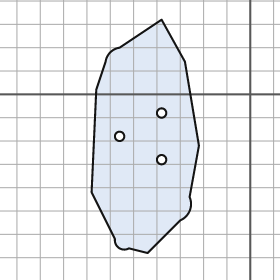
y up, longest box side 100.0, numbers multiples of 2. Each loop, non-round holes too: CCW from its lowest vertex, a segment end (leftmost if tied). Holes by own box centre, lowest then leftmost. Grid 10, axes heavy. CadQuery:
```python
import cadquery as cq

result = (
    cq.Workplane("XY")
    .moveTo(-44.0, -68.0)
    .lineTo(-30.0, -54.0)
    .threePointArc((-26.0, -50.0), (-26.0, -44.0))
    .lineTo(-22.0, -22.0)
    .lineTo(-28.0, 14.0)
    .lineTo(-38.0, 32.0)
    .lineTo(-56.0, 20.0)
    .threePointArc((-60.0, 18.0), (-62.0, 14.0))
    .lineTo(-66.0, 2.0)
    .lineTo(-68.0, -42.0)
    .lineTo(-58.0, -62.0)
    .threePointArc((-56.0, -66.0), (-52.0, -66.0))
    .close()
    .moveTo(-38.0, -28.0)
    .circle(2.0)
    .moveTo(-56.0, -18.0)
    .circle(2.0)
    .moveTo(-38.0, -8.0)
    .circle(2.0)
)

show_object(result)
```